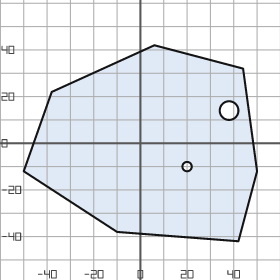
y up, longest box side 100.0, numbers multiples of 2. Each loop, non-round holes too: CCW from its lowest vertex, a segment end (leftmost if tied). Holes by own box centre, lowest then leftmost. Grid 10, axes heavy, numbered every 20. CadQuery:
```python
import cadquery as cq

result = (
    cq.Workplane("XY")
    .moveTo(42.0, -42.0)
    .lineTo(50.0, -12.0)
    .lineTo(44.0, 32.0)
    .lineTo(6.0, 42.0)
    .lineTo(-38.0, 22.0)
    .lineTo(-50.0, -12.0)
    .lineTo(-10.0, -38.0)
    .close()
    .moveTo(20.0, -10.0)
    .circle(2.0)
    .moveTo(38.0, 14.0)
    .circle(4.0)
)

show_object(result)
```